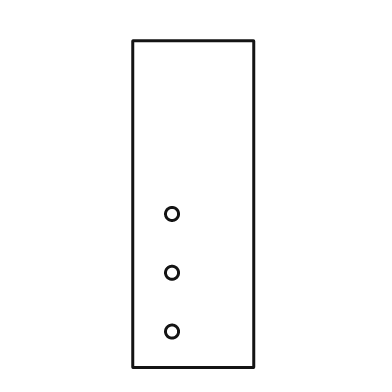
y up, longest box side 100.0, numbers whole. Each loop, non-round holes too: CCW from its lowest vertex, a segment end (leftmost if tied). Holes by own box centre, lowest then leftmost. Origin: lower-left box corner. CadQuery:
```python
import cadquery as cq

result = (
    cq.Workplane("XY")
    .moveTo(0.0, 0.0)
    .lineTo(37.0, 0.0)
    .lineTo(37.0, 100.0)
    .lineTo(0.0, 100.0)
    .close()
    .moveTo(12.0, 11.0)
    .circle(2.0)
    .moveTo(12.0, 29.0)
    .circle(2.0)
    .moveTo(12.0, 47.0)
    .circle(2.0)
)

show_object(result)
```